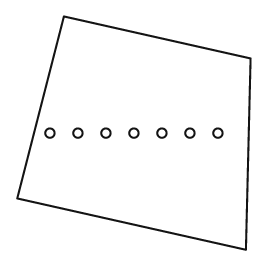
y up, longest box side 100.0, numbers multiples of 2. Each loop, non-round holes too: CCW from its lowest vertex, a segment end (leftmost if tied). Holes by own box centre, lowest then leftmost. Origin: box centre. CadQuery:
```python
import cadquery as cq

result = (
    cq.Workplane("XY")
    .moveTo(48.0, -50.0)
    .lineTo(50.0, 32.0)
    .lineTo(-30.0, 50.0)
    .lineTo(-50.0, -28.0)
    .close()
    .moveTo(-36.0, 0.0)
    .circle(2.0)
    .moveTo(-24.0, 0.0)
    .circle(2.0)
    .moveTo(-12.0, 0.0)
    .circle(2.0)
    .moveTo(0.0, 0.0)
    .circle(2.0)
    .moveTo(12.0, 0.0)
    .circle(2.0)
    .moveTo(24.0, 0.0)
    .circle(2.0)
    .moveTo(36.0, 0.0)
    .circle(2.0)
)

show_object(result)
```